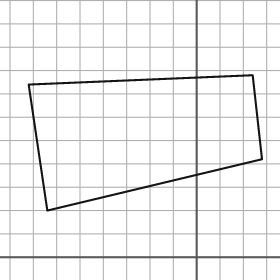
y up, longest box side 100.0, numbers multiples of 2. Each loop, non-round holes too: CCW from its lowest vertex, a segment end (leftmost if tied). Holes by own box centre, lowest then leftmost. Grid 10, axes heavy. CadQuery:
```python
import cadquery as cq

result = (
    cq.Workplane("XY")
    .moveTo(-64.0, 20.0)
    .lineTo(28.0, 42.0)
    .lineTo(24.0, 78.0)
    .lineTo(-72.0, 74.0)
    .close()
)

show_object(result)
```